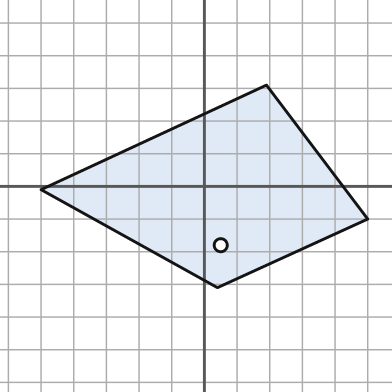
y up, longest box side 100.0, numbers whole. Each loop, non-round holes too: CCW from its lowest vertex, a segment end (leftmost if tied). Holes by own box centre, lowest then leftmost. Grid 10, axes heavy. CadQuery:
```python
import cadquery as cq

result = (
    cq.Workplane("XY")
    .moveTo(4.0, -31.0)
    .lineTo(50.0, -10.0)
    .lineTo(19.0, 31.0)
    .lineTo(-50.0, -1.0)
    .close()
    .moveTo(5.0, -18.0)
    .circle(2.0)
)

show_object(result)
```